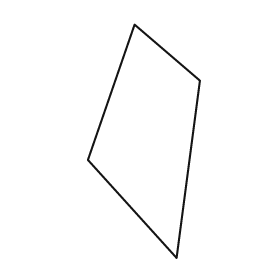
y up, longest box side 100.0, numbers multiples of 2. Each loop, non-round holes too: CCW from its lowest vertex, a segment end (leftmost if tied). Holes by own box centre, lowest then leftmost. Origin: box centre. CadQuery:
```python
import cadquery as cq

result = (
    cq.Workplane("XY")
    .moveTo(14.0, -50.0)
    .lineTo(24.0, 26.0)
    .lineTo(-4.0, 50.0)
    .lineTo(-24.0, -8.0)
    .close()
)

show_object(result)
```